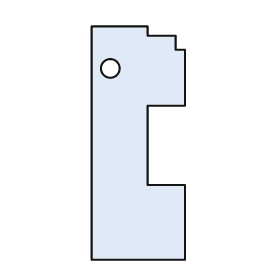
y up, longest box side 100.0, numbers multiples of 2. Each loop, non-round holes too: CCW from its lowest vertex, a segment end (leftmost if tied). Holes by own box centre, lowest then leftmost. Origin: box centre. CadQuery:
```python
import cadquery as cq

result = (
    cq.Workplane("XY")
    .moveTo(-20.0, -50.0)
    .lineTo(20.0, -50.0)
    .lineTo(20.0, -18.0)
    .lineTo(4.0, -18.0)
    .lineTo(4.0, 16.0)
    .lineTo(20.0, 16.0)
    .lineTo(20.0, 40.0)
    .lineTo(16.0, 40.0)
    .lineTo(16.0, 46.0)
    .lineTo(4.0, 46.0)
    .lineTo(4.0, 50.0)
    .lineTo(-20.0, 50.0)
    .close()
    .moveTo(-12.0, 32.0)
    .circle(4.0)
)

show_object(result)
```